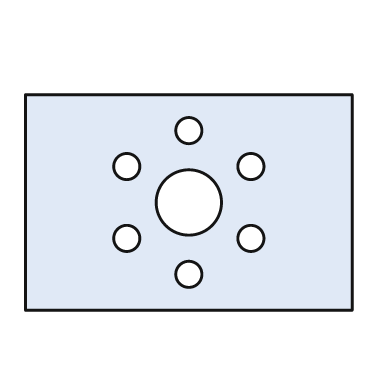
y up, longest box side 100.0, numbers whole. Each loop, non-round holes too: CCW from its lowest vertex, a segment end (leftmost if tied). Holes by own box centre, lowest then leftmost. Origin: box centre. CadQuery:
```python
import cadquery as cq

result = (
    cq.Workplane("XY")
    .moveTo(-50.0, -33.0)
    .lineTo(50.0, -33.0)
    .lineTo(50.0, 33.0)
    .lineTo(-50.0, 33.0)
    .close()
    .moveTo(0.0, -22.0)
    .circle(4.0)
    .moveTo(-19.0, -11.0)
    .circle(4.0)
    .moveTo(19.0, -11.0)
    .circle(4.0)
    .moveTo(0.0, 0.0)
    .circle(10.0)
    .moveTo(-19.0, 11.0)
    .circle(4.0)
    .moveTo(19.0, 11.0)
    .circle(4.0)
    .moveTo(0.0, 22.0)
    .circle(4.0)
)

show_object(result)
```